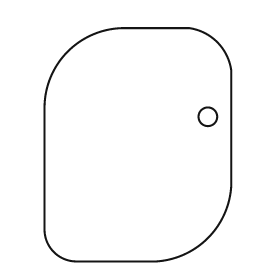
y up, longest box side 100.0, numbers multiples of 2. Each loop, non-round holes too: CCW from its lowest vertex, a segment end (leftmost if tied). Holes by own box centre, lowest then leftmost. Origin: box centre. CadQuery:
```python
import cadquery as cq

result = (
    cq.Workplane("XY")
    .moveTo(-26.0, -50.0)
    .lineTo(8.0, -50.0)
    .threePointArc((30.0, -40.0), (40.0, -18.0))
    .lineTo(40.0, 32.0)
    .threePointArc((34.0, 44.0), (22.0, 50.0))
    .lineTo(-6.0, 50.0)
    .threePointArc((-30.0, 40.0), (-40.0, 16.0))
    .lineTo(-40.0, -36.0)
    .threePointArc((-36.0, -46.0), (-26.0, -50.0))
    .close()
    .moveTo(30.0, 12.0)
    .circle(4.0)
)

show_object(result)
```